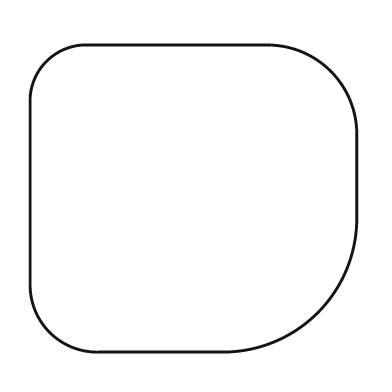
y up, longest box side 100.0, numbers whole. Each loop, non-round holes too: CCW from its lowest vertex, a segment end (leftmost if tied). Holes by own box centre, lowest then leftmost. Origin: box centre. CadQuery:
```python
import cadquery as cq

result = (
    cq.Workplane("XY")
    .moveTo(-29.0, -47.0)
    .lineTo(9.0, -47.0)
    .threePointArc((38.0, -35.0), (50.0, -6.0))
    .lineTo(50.0, 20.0)
    .threePointArc((42.0, 39.0), (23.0, 47.0))
    .lineTo(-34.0, 47.0)
    .threePointArc((-45.0, 42.0), (-50.0, 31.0))
    .lineTo(-50.0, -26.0)
    .threePointArc((-44.0, -41.0), (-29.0, -47.0))
    .close()
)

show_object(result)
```